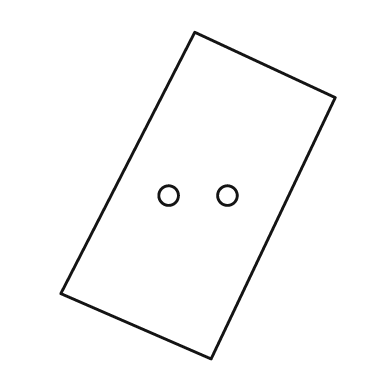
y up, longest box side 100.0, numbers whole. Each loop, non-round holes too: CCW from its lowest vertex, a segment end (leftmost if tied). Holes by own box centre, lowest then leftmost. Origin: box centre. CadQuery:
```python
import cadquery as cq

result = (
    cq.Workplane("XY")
    .moveTo(4.0, -50.0)
    .lineTo(42.0, 30.0)
    .lineTo(-1.0, 50.0)
    .lineTo(-42.0, -30.0)
    .close()
    .moveTo(-9.0, 0.0)
    .circle(3.0)
    .moveTo(9.0, 0.0)
    .circle(3.0)
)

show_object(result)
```